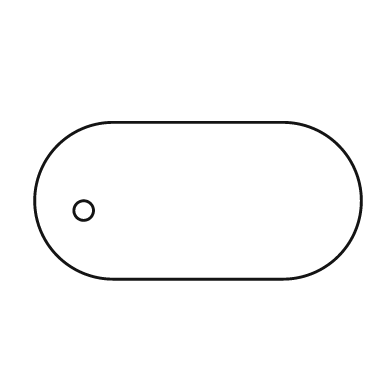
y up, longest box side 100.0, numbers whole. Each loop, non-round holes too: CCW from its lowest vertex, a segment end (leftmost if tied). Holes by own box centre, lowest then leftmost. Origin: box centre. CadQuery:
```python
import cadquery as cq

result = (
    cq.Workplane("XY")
    .moveTo(-26.0, -24.0)
    .lineTo(26.0, -24.0)
    .threePointArc((50.0, 0.0), (26.0, 24.0))
    .lineTo(-26.0, 24.0)
    .threePointArc((-50.0, 0.0), (-26.0, -24.0))
    .close()
    .moveTo(-35.0, -3.0)
    .circle(3.0)
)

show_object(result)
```